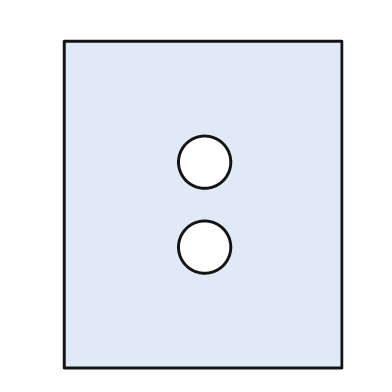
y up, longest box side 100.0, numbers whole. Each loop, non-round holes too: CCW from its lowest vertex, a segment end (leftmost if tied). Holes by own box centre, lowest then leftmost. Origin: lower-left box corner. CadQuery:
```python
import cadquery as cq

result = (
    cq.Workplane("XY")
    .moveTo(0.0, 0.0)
    .lineTo(85.0, 0.0)
    .lineTo(85.0, 100.0)
    .lineTo(0.0, 100.0)
    .close()
    .moveTo(43.0, 37.0)
    .circle(8.0)
    .moveTo(43.0, 63.0)
    .circle(8.0)
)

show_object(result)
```